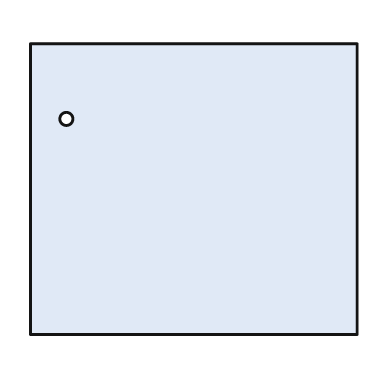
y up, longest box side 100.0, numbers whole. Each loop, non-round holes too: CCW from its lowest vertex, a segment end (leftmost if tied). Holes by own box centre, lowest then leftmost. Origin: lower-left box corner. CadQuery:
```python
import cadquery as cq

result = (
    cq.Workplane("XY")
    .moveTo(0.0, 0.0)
    .lineTo(100.0, 0.0)
    .lineTo(100.0, 89.0)
    .lineTo(0.0, 89.0)
    .close()
    .moveTo(11.0, 66.0)
    .circle(2.0)
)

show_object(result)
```